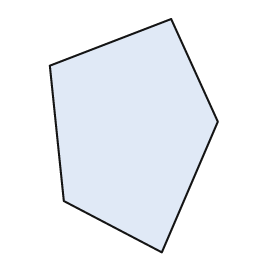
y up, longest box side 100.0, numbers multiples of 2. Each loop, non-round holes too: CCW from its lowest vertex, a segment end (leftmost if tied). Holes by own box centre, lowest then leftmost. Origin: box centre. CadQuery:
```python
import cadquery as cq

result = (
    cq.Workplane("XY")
    .moveTo(12.0, -50.0)
    .lineTo(36.0, 6.0)
    .lineTo(16.0, 50.0)
    .lineTo(-36.0, 30.0)
    .lineTo(-30.0, -28.0)
    .close()
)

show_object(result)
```